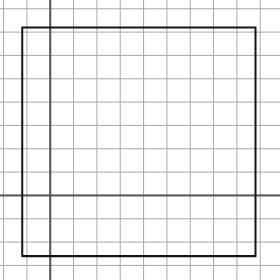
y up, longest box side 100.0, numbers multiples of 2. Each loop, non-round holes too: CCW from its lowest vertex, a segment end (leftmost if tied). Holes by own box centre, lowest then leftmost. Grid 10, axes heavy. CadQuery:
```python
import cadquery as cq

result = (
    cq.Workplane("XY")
    .moveTo(-12.0, -26.0)
    .lineTo(88.0, -26.0)
    .lineTo(88.0, 72.0)
    .lineTo(-12.0, 72.0)
    .close()
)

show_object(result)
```